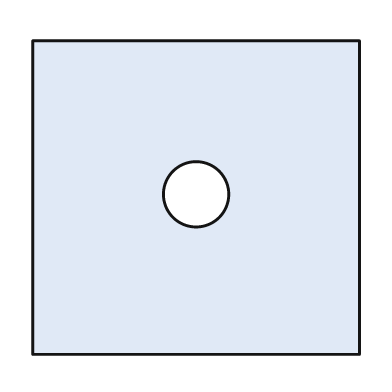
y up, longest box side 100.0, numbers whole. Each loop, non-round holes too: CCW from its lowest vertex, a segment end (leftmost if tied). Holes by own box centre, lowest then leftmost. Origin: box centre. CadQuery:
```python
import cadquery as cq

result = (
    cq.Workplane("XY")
    .moveTo(-50.0, -48.0)
    .lineTo(50.0, -48.0)
    .lineTo(50.0, 48.0)
    .lineTo(-50.0, 48.0)
    .close()
    .moveTo(0.0, 1.0)
    .circle(10.0)
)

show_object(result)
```